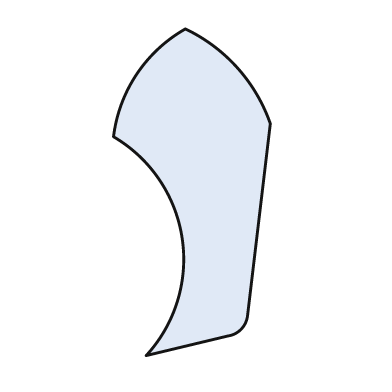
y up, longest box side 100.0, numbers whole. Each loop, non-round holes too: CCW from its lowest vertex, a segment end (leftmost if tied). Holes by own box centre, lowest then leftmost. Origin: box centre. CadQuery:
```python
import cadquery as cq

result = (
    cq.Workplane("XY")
    .moveTo(-14.0, -50.0)
    .lineTo(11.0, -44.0)
    .threePointArc((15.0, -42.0), (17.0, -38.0))
    .lineTo(24.0, 21.0)
    .threePointArc((14.0, 38.0), (-2.0, 50.0))
    .threePointArc((-17.0, 36.0), (-24.0, 17.0))
    .threePointArc((-3.0, -14.0), (-14.0, -50.0))
    .close()
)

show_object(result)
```